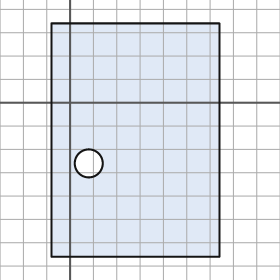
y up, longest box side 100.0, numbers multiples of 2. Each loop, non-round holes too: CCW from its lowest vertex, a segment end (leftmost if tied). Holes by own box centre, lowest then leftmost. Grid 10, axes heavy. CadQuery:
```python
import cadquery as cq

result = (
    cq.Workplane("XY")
    .moveTo(-8.0, -66.0)
    .lineTo(64.0, -66.0)
    .lineTo(64.0, 34.0)
    .lineTo(-8.0, 34.0)
    .close()
    .moveTo(8.0, -26.0)
    .circle(6.0)
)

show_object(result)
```